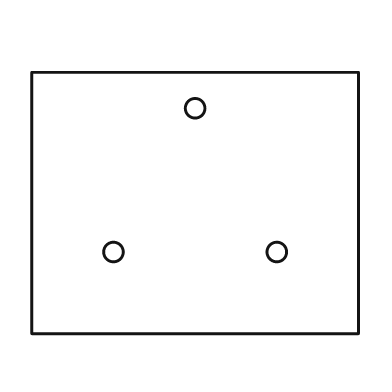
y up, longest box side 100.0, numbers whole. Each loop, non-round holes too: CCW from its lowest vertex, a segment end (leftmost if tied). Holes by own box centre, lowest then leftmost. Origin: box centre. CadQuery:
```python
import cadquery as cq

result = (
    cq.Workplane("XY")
    .moveTo(-50.0, -40.0)
    .lineTo(50.0, -40.0)
    .lineTo(50.0, 40.0)
    .lineTo(-50.0, 40.0)
    .close()
    .moveTo(-25.0, -15.0)
    .circle(3.0)
    .moveTo(25.0, -15.0)
    .circle(3.0)
    .moveTo(0.0, 29.0)
    .circle(3.0)
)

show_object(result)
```